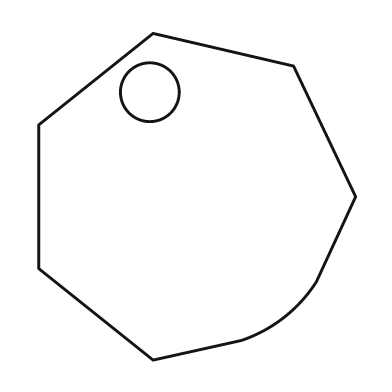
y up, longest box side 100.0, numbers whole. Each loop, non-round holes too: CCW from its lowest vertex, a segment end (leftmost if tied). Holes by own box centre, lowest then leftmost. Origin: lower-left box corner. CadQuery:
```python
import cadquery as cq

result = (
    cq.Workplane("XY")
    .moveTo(35.0, 0.0)
    .lineTo(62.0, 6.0)
    .threePointArc((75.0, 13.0), (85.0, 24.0))
    .lineTo(97.0, 50.0)
    .lineTo(78.0, 90.0)
    .lineTo(35.0, 100.0)
    .lineTo(0.0, 72.0)
    .lineTo(0.0, 28.0)
    .close()
    .moveTo(34.0, 82.0)
    .circle(9.0)
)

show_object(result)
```